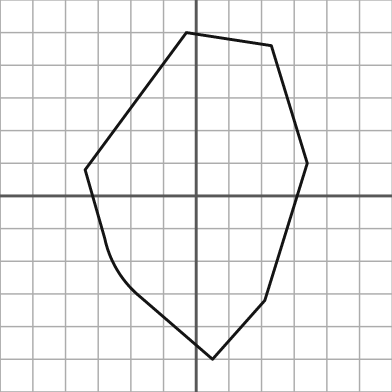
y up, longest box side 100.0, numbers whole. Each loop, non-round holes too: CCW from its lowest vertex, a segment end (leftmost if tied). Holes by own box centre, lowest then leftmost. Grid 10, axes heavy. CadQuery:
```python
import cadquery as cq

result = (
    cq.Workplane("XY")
    .moveTo(5.0, -50.0)
    .lineTo(21.0, -32.0)
    .lineTo(34.0, 10.0)
    .lineTo(23.0, 46.0)
    .lineTo(-3.0, 50.0)
    .lineTo(-34.0, 8.0)
    .lineTo(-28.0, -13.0)
    .threePointArc((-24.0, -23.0), (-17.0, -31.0))
    .close()
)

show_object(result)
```